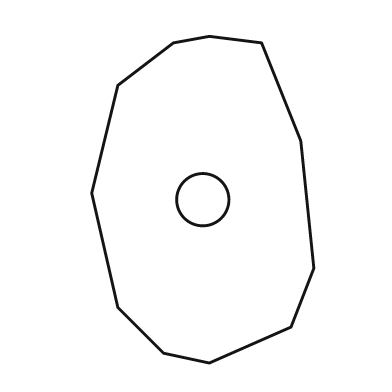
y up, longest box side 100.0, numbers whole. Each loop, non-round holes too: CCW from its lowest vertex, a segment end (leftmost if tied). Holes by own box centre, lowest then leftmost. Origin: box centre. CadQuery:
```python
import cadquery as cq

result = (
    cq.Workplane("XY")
    .moveTo(2.0, -50.0)
    .lineTo(27.0, -39.0)
    .lineTo(34.0, -21.0)
    .lineTo(30.0, 18.0)
    .lineTo(18.0, 48.0)
    .lineTo(2.0, 50.0)
    .lineTo(-9.0, 48.0)
    .lineTo(-26.0, 35.0)
    .lineTo(-34.0, 2.0)
    .lineTo(-26.0, -33.0)
    .lineTo(-12.0, -47.0)
    .close()
    .moveTo(0.0, 0.0)
    .circle(8.0)
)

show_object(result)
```